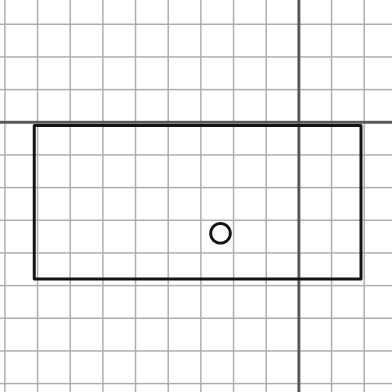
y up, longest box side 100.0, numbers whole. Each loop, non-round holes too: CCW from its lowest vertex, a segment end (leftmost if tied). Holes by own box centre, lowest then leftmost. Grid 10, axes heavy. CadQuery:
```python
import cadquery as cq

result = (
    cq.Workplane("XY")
    .moveTo(-81.0, -48.0)
    .lineTo(19.0, -48.0)
    .lineTo(19.0, -1.0)
    .lineTo(-81.0, -1.0)
    .close()
    .moveTo(-24.0, -34.0)
    .circle(3.0)
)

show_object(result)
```